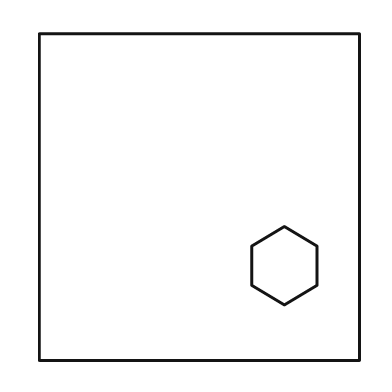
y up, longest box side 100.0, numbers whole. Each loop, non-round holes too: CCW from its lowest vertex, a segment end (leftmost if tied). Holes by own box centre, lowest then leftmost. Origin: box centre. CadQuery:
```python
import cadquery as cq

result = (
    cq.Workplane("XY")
    .moveTo(-49.0, -50.0)
    .lineTo(49.0, -50.0)
    .lineTo(49.0, 50.0)
    .lineTo(-49.0, 50.0)
    .close()
    .moveTo(26.0, -33.0)
    .lineTo(36.0, -27.0)
    .lineTo(36.0, -15.0)
    .lineTo(26.0, -9.0)
    .lineTo(16.0, -15.0)
    .lineTo(16.0, -27.0)
    .close()
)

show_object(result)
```